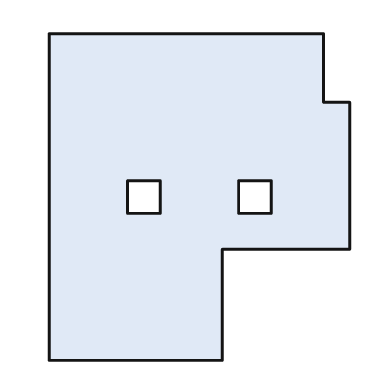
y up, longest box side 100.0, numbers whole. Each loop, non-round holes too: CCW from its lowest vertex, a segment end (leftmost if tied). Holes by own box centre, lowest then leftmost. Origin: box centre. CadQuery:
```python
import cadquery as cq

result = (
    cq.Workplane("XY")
    .moveTo(-46.0, -50.0)
    .lineTo(7.0, -50.0)
    .lineTo(7.0, -16.0)
    .lineTo(46.0, -16.0)
    .lineTo(46.0, 29.0)
    .lineTo(38.0, 29.0)
    .lineTo(38.0, 50.0)
    .lineTo(-46.0, 50.0)
    .close()
    .moveTo(-22.0, -5.0)
    .lineTo(-12.0, -5.0)
    .lineTo(-12.0, 5.0)
    .lineTo(-22.0, 5.0)
    .close()
    .moveTo(12.0, -5.0)
    .lineTo(22.0, -5.0)
    .lineTo(22.0, 5.0)
    .lineTo(12.0, 5.0)
    .close()
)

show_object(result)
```